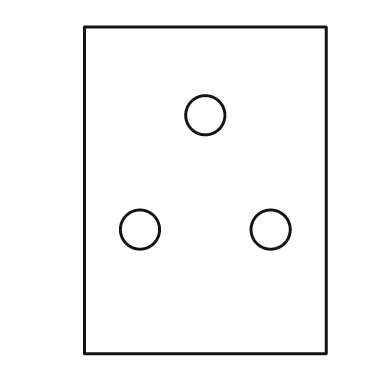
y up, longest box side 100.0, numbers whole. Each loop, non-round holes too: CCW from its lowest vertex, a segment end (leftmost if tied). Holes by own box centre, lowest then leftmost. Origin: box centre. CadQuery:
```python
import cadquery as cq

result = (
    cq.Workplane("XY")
    .moveTo(-37.0, -50.0)
    .lineTo(37.0, -50.0)
    .lineTo(37.0, 50.0)
    .lineTo(-37.0, 50.0)
    .close()
    .moveTo(-20.0, -12.0)
    .circle(6.0)
    .moveTo(20.0, -12.0)
    .circle(6.0)
    .moveTo(0.0, 23.0)
    .circle(6.0)
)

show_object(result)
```